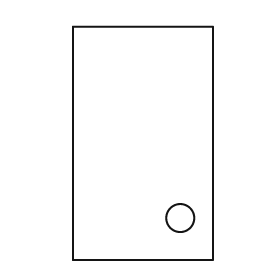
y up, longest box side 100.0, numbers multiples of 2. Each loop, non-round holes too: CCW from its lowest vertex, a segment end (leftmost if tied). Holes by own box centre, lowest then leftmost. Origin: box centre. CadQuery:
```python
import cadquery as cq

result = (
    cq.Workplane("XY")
    .moveTo(-30.0, -50.0)
    .lineTo(30.0, -50.0)
    .lineTo(30.0, 50.0)
    .lineTo(-30.0, 50.0)
    .close()
    .moveTo(16.0, -32.0)
    .circle(6.0)
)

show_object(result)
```